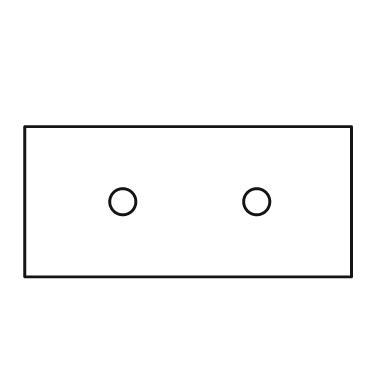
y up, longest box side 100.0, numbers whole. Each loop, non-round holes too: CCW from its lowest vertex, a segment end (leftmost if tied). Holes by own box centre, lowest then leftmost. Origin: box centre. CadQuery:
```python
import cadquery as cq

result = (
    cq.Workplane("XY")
    .moveTo(-50.0, -23.0)
    .lineTo(50.0, -23.0)
    .lineTo(50.0, 23.0)
    .lineTo(-50.0, 23.0)
    .close()
    .moveTo(-20.0, 0.0)
    .circle(4.0)
    .moveTo(21.0, 0.0)
    .circle(4.0)
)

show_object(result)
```